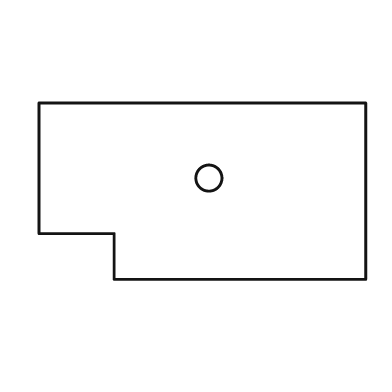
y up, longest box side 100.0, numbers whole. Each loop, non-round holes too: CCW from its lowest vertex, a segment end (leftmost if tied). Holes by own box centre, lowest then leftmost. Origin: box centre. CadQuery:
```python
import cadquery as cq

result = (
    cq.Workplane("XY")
    .moveTo(-27.0, -27.0)
    .lineTo(50.0, -27.0)
    .lineTo(50.0, 27.0)
    .lineTo(-50.0, 27.0)
    .lineTo(-50.0, -13.0)
    .lineTo(-27.0, -13.0)
    .close()
    .moveTo(2.0, 4.0)
    .circle(4.0)
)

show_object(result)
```